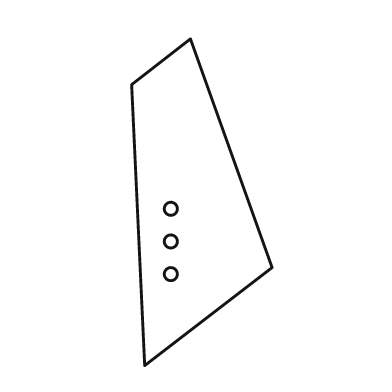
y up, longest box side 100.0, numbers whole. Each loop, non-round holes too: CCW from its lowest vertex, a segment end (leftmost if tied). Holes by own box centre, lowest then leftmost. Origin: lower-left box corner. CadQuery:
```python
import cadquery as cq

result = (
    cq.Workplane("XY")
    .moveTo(4.0, 0.0)
    .lineTo(43.0, 30.0)
    .lineTo(18.0, 100.0)
    .lineTo(0.0, 86.0)
    .close()
    .moveTo(12.0, 28.0)
    .circle(2.0)
    .moveTo(12.0, 38.0)
    .circle(2.0)
    .moveTo(12.0, 48.0)
    .circle(2.0)
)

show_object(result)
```